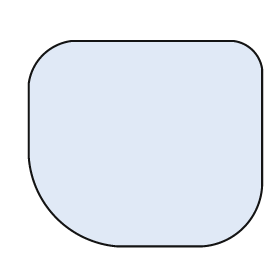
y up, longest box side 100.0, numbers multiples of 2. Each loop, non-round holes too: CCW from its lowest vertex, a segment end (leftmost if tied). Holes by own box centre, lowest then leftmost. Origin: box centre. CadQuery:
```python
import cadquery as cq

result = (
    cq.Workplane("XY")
    .moveTo(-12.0, -44.0)
    .lineTo(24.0, -44.0)
    .threePointArc((42.0, -36.0), (50.0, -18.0))
    .lineTo(50.0, 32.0)
    .threePointArc((46.0, 40.0), (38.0, 44.0))
    .lineTo(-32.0, 44.0)
    .threePointArc((-44.0, 38.0), (-50.0, 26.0))
    .lineTo(-50.0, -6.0)
    .threePointArc((-38.0, -32.0), (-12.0, -44.0))
    .close()
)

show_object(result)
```